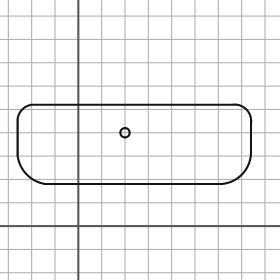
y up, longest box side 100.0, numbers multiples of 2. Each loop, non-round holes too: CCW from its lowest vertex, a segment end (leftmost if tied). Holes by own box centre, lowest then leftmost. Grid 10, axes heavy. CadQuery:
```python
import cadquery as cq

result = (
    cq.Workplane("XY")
    .moveTo(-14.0, 18.0)
    .lineTo(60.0, 18.0)
    .threePointArc((70.0, 22.0), (74.0, 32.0))
    .lineTo(74.0, 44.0)
    .threePointArc((72.0, 50.0), (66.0, 52.0))
    .lineTo(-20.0, 52.0)
    .threePointArc((-24.0, 50.0), (-26.0, 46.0))
    .lineTo(-26.0, 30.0)
    .threePointArc((-22.0, 22.0), (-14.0, 18.0))
    .close()
    .moveTo(20.0, 40.0)
    .circle(2.0)
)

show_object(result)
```